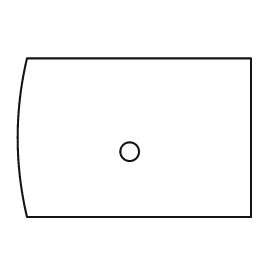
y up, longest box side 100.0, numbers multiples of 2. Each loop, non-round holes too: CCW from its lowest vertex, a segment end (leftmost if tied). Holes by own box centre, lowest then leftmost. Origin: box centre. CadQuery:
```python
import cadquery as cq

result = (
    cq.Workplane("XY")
    .moveTo(-46.0, -34.0)
    .lineTo(50.0, -34.0)
    .lineTo(50.0, 34.0)
    .lineTo(-46.0, 34.0)
    .threePointArc((-50.0, 0.0), (-46.0, -34.0))
    .close()
    .moveTo(-2.0, -6.0)
    .circle(4.0)
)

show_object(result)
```